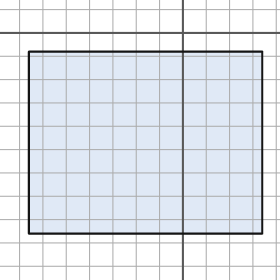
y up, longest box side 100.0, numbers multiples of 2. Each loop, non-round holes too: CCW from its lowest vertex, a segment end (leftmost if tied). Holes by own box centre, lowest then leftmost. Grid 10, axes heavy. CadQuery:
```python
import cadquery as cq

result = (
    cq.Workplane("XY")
    .moveTo(-66.0, -86.0)
    .lineTo(34.0, -86.0)
    .lineTo(34.0, -8.0)
    .lineTo(-66.0, -8.0)
    .close()
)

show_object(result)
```